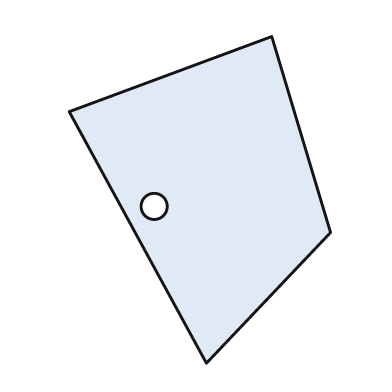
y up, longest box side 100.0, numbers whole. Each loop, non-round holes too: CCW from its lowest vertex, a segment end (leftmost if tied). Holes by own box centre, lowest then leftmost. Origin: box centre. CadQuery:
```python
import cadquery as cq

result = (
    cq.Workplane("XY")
    .moveTo(2.0, -50.0)
    .lineTo(40.0, -10.0)
    .lineTo(22.0, 50.0)
    .lineTo(-40.0, 27.0)
    .close()
    .moveTo(-14.0, -2.0)
    .circle(4.0)
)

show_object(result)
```